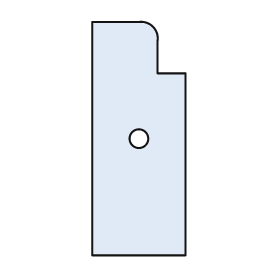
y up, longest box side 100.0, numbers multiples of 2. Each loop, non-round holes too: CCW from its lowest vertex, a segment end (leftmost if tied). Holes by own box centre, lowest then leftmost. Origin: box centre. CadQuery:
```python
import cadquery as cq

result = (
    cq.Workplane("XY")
    .moveTo(-20.0, -50.0)
    .lineTo(20.0, -50.0)
    .lineTo(20.0, 28.0)
    .lineTo(8.0, 28.0)
    .lineTo(8.0, 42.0)
    .threePointArc((6.0, 48.0), (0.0, 50.0))
    .lineTo(-20.0, 50.0)
    .close()
    .moveTo(0.0, 0.0)
    .circle(4.0)
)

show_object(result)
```